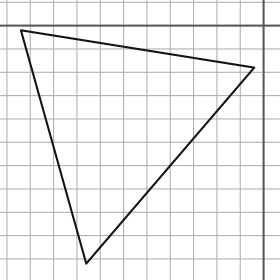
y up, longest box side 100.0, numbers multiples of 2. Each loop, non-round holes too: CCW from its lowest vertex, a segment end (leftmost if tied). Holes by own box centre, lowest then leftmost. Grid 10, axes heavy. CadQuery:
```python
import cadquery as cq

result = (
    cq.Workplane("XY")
    .moveTo(-76.0, -102.0)
    .lineTo(-4.0, -18.0)
    .lineTo(-104.0, -2.0)
    .close()
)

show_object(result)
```